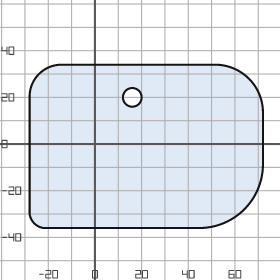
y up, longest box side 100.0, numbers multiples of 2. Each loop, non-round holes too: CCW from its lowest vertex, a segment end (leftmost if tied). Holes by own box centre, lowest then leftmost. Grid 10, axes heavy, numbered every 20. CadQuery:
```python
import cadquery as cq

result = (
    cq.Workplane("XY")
    .moveTo(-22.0, -36.0)
    .lineTo(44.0, -36.0)
    .threePointArc((64.0, -28.0), (72.0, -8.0))
    .lineTo(72.0, 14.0)
    .threePointArc((66.0, 28.0), (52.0, 34.0))
    .lineTo(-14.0, 34.0)
    .threePointArc((-24.0, 30.0), (-28.0, 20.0))
    .lineTo(-28.0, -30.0)
    .threePointArc((-26.0, -34.0), (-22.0, -36.0))
    .close()
    .moveTo(16.0, 20.0)
    .circle(4.0)
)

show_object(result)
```